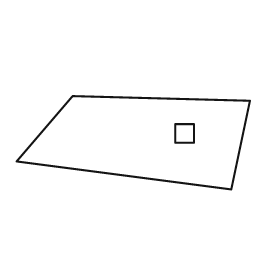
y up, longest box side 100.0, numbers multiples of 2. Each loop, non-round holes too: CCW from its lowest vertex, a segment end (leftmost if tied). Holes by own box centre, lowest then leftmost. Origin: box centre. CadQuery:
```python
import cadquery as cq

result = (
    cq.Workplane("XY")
    .moveTo(42.0, -20.0)
    .lineTo(50.0, 18.0)
    .lineTo(-26.0, 20.0)
    .lineTo(-50.0, -8.0)
    .close()
    .moveTo(18.0, 0.0)
    .lineTo(26.0, 0.0)
    .lineTo(26.0, 8.0)
    .lineTo(18.0, 8.0)
    .close()
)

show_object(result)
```